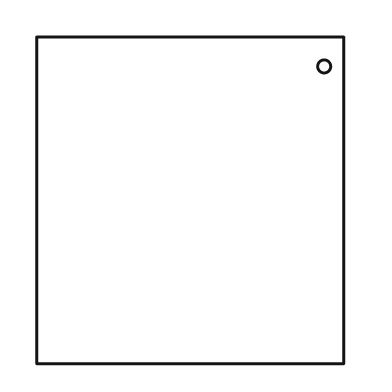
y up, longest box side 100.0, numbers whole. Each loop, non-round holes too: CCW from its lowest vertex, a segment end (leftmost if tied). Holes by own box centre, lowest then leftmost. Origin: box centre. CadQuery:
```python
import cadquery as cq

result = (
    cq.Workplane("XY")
    .moveTo(-47.0, -50.0)
    .lineTo(47.0, -50.0)
    .lineTo(47.0, 50.0)
    .lineTo(-47.0, 50.0)
    .close()
    .moveTo(41.0, 41.0)
    .circle(2.0)
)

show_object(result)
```